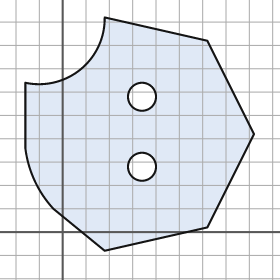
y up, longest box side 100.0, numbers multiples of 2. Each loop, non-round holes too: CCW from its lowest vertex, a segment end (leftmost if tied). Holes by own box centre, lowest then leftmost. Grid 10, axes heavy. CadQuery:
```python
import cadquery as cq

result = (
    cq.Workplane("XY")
    .moveTo(18.0, -8.0)
    .lineTo(62.0, 2.0)
    .lineTo(82.0, 42.0)
    .lineTo(62.0, 82.0)
    .lineTo(18.0, 92.0)
    .threePointArc((8.0, 70.0), (-16.0, 64.0))
    .lineTo(-16.0, 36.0)
    .threePointArc((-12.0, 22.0), (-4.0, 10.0))
    .close()
    .moveTo(34.0, 28.0)
    .circle(6.0)
    .moveTo(34.0, 58.0)
    .circle(6.0)
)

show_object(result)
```